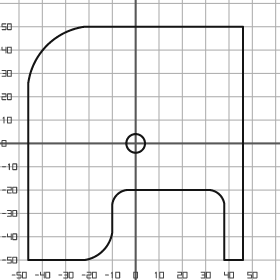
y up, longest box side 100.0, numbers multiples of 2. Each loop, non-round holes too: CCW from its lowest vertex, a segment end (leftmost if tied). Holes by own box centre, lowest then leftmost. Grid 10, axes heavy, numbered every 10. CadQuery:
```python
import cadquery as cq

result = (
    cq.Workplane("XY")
    .moveTo(-46.0, -50.0)
    .lineTo(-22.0, -50.0)
    .threePointArc((-14.0, -46.0), (-10.0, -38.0))
    .lineTo(-10.0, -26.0)
    .threePointArc((-8.0, -22.0), (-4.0, -20.0))
    .lineTo(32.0, -20.0)
    .threePointArc((36.0, -22.0), (38.0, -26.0))
    .lineTo(38.0, -50.0)
    .lineTo(46.0, -50.0)
    .lineTo(46.0, 50.0)
    .lineTo(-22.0, 50.0)
    .threePointArc((-38.0, 42.0), (-46.0, 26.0))
    .close()
    .moveTo(0.0, 0.0)
    .circle(4.0)
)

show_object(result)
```